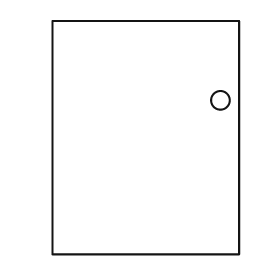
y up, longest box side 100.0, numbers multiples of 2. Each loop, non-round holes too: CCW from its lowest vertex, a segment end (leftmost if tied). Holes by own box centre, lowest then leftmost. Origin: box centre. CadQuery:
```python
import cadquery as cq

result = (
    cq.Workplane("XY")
    .moveTo(-40.0, -50.0)
    .lineTo(40.0, -50.0)
    .lineTo(40.0, 50.0)
    .lineTo(-40.0, 50.0)
    .close()
    .moveTo(32.0, 16.0)
    .circle(4.0)
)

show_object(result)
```